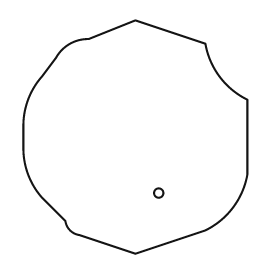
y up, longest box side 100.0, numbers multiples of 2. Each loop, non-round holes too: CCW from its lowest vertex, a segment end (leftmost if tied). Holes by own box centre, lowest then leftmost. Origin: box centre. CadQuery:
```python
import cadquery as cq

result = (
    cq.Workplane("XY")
    .moveTo(0.0, -50.0)
    .lineTo(30.0, -40.0)
    .threePointArc((42.0, -30.0), (48.0, -16.0))
    .lineTo(48.0, 16.0)
    .threePointArc((36.0, 26.0), (30.0, 40.0))
    .lineTo(0.0, 50.0)
    .lineTo(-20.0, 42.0)
    .threePointArc((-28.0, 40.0), (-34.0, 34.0))
    .lineTo(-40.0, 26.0)
    .threePointArc((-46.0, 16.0), (-48.0, 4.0))
    .lineTo(-48.0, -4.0)
    .threePointArc((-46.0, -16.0), (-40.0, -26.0))
    .lineTo(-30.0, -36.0)
    .threePointArc((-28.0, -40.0), (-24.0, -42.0))
    .close()
    .moveTo(10.0, -24.0)
    .circle(2.0)
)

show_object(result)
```